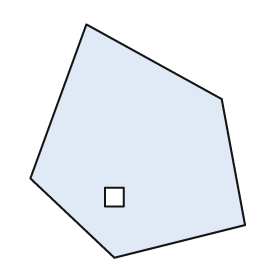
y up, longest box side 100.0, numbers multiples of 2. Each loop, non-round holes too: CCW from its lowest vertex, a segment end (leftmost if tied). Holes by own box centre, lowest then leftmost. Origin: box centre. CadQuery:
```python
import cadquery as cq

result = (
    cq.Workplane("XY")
    .moveTo(-10.0, -50.0)
    .lineTo(46.0, -36.0)
    .lineTo(36.0, 18.0)
    .lineTo(-22.0, 50.0)
    .lineTo(-46.0, -16.0)
    .close()
    .moveTo(-14.0, -28.0)
    .lineTo(-6.0, -28.0)
    .lineTo(-6.0, -20.0)
    .lineTo(-14.0, -20.0)
    .close()
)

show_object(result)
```